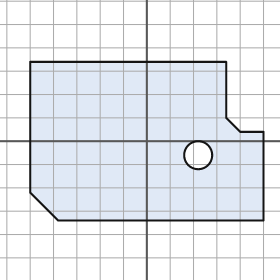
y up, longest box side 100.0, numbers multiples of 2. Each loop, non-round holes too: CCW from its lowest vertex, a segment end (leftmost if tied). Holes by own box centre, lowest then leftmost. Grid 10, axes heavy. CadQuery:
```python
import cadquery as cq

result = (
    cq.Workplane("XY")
    .moveTo(-38.0, -34.0)
    .lineTo(50.0, -34.0)
    .lineTo(50.0, 4.0)
    .lineTo(40.0, 4.0)
    .lineTo(34.0, 10.0)
    .lineTo(34.0, 34.0)
    .lineTo(-50.0, 34.0)
    .lineTo(-50.0, -22.0)
    .close()
    .moveTo(22.0, -6.0)
    .circle(6.0)
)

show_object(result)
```